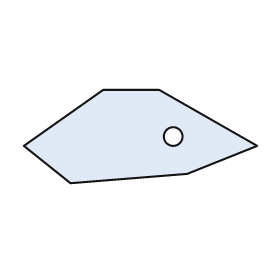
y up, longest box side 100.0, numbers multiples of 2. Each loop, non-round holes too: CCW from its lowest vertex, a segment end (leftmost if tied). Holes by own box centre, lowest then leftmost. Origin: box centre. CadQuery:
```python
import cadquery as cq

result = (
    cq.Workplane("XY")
    .moveTo(-30.0, -20.0)
    .lineTo(20.0, -16.0)
    .lineTo(50.0, -4.0)
    .lineTo(8.0, 20.0)
    .lineTo(-16.0, 20.0)
    .lineTo(-50.0, -4.0)
    .close()
    .moveTo(14.0, 0.0)
    .circle(4.0)
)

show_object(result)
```